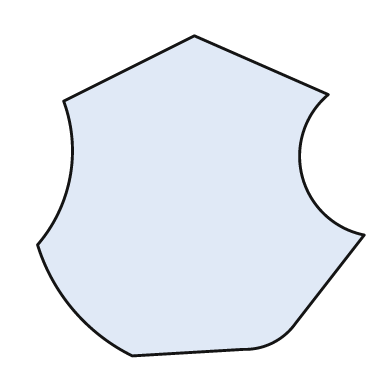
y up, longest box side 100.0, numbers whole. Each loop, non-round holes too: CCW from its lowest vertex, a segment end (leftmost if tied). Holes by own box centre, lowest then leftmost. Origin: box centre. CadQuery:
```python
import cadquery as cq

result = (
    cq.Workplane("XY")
    .moveTo(-21.0, -49.0)
    .lineTo(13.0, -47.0)
    .threePointArc((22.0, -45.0), (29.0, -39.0))
    .lineTo(50.0, -12.0)
    .threePointArc((31.0, 6.0), (39.0, 31.0))
    .lineTo(-2.0, 49.0)
    .lineTo(-42.0, 29.0)
    .threePointArc((-40.0, 6.0), (-50.0, -15.0))
    .threePointArc((-39.0, -35.0), (-21.0, -49.0))
    .close()
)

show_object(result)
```